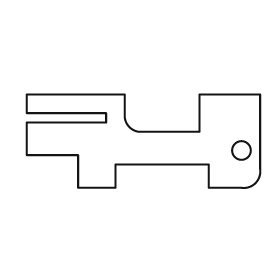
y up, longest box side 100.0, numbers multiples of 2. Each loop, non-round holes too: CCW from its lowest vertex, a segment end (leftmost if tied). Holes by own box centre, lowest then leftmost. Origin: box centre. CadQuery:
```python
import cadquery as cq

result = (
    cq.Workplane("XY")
    .moveTo(-28.0, -20.0)
    .lineTo(-12.0, -20.0)
    .lineTo(-12.0, -10.0)
    .lineTo(28.0, -10.0)
    .lineTo(28.0, -20.0)
    .lineTo(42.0, -20.0)
    .threePointArc((48.0, -18.0), (50.0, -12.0))
    .lineTo(50.0, 20.0)
    .lineTo(24.0, 20.0)
    .lineTo(24.0, 4.0)
    .lineTo(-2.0, 4.0)
    .threePointArc((-6.0, 6.0), (-8.0, 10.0))
    .lineTo(-8.0, 20.0)
    .lineTo(-50.0, 20.0)
    .lineTo(-50.0, 12.0)
    .lineTo(-16.0, 12.0)
    .lineTo(-16.0, 8.0)
    .lineTo(-50.0, 8.0)
    .lineTo(-50.0, -6.0)
    .lineTo(-28.0, -6.0)
    .close()
    .moveTo(42.0, -4.0)
    .circle(4.0)
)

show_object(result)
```